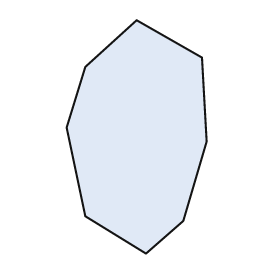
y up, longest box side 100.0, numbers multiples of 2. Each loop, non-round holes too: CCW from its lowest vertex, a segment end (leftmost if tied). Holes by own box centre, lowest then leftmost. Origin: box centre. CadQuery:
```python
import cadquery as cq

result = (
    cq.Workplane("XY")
    .moveTo(4.0, -50.0)
    .lineTo(20.0, -36.0)
    .lineTo(30.0, -2.0)
    .lineTo(28.0, 34.0)
    .lineTo(0.0, 50.0)
    .lineTo(-22.0, 30.0)
    .lineTo(-30.0, 4.0)
    .lineTo(-22.0, -34.0)
    .close()
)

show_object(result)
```